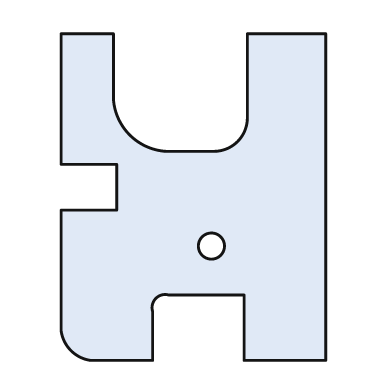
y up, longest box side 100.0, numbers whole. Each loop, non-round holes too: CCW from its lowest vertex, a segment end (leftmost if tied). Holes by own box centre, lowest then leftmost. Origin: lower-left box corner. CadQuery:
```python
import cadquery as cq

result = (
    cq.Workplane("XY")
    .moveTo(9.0, 0.0)
    .lineTo(28.0, 0.0)
    .lineTo(28.0, 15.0)
    .threePointArc((29.0, 19.0), (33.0, 20.0))
    .lineTo(56.0, 20.0)
    .lineTo(56.0, 0.0)
    .lineTo(81.0, 0.0)
    .lineTo(81.0, 100.0)
    .lineTo(57.0, 100.0)
    .lineTo(57.0, 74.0)
    .threePointArc((54.0, 67.0), (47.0, 64.0))
    .lineTo(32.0, 64.0)
    .threePointArc((21.0, 69.0), (16.0, 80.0))
    .lineTo(16.0, 100.0)
    .lineTo(0.0, 100.0)
    .lineTo(0.0, 60.0)
    .lineTo(17.0, 60.0)
    .lineTo(17.0, 46.0)
    .lineTo(0.0, 46.0)
    .lineTo(0.0, 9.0)
    .threePointArc((3.0, 3.0), (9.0, 0.0))
    .close()
    .moveTo(46.0, 35.0)
    .circle(4.0)
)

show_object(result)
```